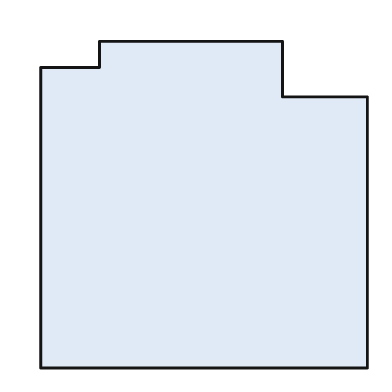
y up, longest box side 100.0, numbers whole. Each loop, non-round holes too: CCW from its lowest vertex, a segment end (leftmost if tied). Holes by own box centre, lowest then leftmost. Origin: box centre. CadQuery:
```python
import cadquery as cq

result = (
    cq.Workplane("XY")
    .moveTo(-50.0, -50.0)
    .lineTo(50.0, -50.0)
    .lineTo(50.0, 33.0)
    .lineTo(24.0, 33.0)
    .lineTo(24.0, 50.0)
    .lineTo(-32.0, 50.0)
    .lineTo(-32.0, 42.0)
    .lineTo(-50.0, 42.0)
    .close()
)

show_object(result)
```